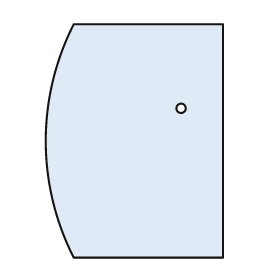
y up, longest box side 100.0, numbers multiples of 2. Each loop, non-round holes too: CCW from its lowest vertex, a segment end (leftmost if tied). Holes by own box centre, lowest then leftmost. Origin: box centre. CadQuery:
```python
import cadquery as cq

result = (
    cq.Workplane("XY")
    .moveTo(-26.0, -50.0)
    .lineTo(38.0, -50.0)
    .lineTo(38.0, 50.0)
    .lineTo(-26.0, 50.0)
    .threePointArc((-38.0, 0.0), (-26.0, -50.0))
    .close()
    .moveTo(20.0, 14.0)
    .circle(2.0)
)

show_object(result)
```